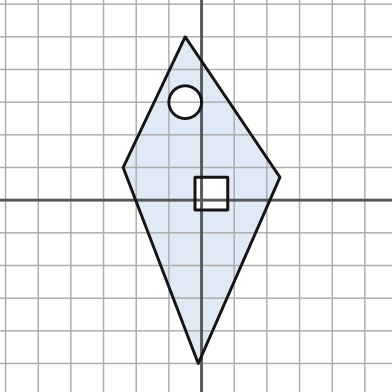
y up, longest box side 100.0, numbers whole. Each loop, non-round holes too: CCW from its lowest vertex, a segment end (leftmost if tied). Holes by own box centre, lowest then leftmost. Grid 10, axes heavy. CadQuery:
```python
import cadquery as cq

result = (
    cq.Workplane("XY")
    .moveTo(-1.0, -50.0)
    .lineTo(24.0, 7.0)
    .lineTo(-5.0, 50.0)
    .lineTo(-24.0, 10.0)
    .close()
    .moveTo(-2.0, -3.0)
    .lineTo(8.0, -3.0)
    .lineTo(8.0, 7.0)
    .lineTo(-2.0, 7.0)
    .close()
    .moveTo(-5.0, 30.0)
    .circle(5.0)
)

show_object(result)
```